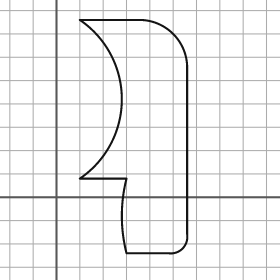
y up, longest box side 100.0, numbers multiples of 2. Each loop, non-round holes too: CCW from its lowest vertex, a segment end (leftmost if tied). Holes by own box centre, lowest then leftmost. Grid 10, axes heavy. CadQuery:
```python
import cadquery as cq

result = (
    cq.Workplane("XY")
    .moveTo(30.0, -24.0)
    .lineTo(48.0, -24.0)
    .threePointArc((54.0, -22.0), (56.0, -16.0))
    .lineTo(56.0, 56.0)
    .threePointArc((50.0, 70.0), (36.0, 76.0))
    .lineTo(10.0, 76.0)
    .threePointArc((28.0, 42.0), (10.0, 8.0))
    .lineTo(30.0, 8.0)
    .threePointArc((28.0, -8.0), (30.0, -24.0))
    .close()
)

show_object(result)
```